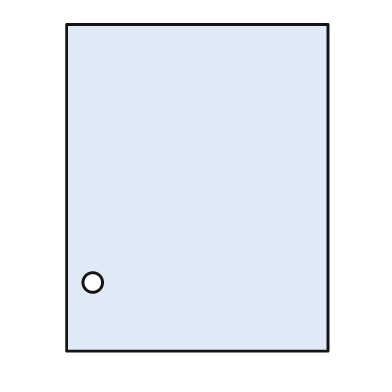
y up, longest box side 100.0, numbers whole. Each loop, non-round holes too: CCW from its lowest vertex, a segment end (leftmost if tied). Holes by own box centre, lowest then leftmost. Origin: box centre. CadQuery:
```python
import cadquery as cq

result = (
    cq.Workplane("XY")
    .moveTo(-40.0, -50.0)
    .lineTo(40.0, -50.0)
    .lineTo(40.0, 50.0)
    .lineTo(-40.0, 50.0)
    .close()
    .moveTo(-32.0, -29.0)
    .circle(3.0)
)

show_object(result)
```